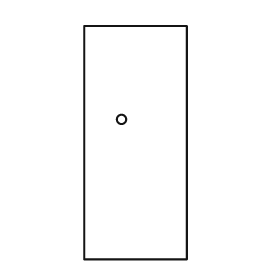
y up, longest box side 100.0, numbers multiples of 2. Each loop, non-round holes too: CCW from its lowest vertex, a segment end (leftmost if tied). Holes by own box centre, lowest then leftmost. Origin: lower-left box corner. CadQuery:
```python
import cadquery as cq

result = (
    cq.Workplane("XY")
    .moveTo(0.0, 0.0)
    .lineTo(44.0, 0.0)
    .lineTo(44.0, 100.0)
    .lineTo(0.0, 100.0)
    .close()
    .moveTo(16.0, 60.0)
    .circle(2.0)
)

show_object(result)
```